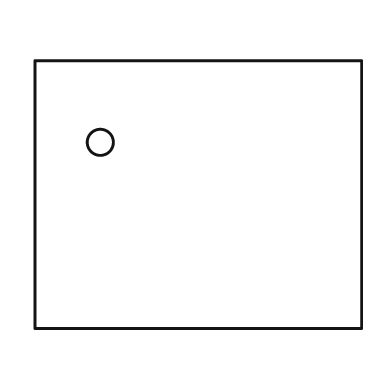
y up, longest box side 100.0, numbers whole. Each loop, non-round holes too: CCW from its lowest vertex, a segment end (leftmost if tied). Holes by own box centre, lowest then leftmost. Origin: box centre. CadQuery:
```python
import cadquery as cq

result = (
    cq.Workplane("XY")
    .moveTo(-50.0, -41.0)
    .lineTo(50.0, -41.0)
    .lineTo(50.0, 41.0)
    .lineTo(-50.0, 41.0)
    .close()
    .moveTo(-30.0, 16.0)
    .circle(4.0)
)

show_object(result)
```